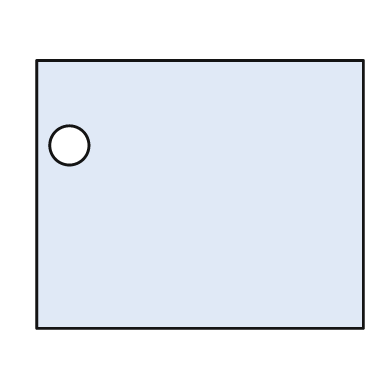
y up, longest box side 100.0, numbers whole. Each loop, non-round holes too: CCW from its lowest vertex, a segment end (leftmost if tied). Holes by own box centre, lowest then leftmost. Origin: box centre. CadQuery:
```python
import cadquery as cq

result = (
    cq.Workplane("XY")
    .moveTo(-50.0, -41.0)
    .lineTo(50.0, -41.0)
    .lineTo(50.0, 41.0)
    .lineTo(-50.0, 41.0)
    .close()
    .moveTo(-40.0, 15.0)
    .circle(6.0)
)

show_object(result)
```